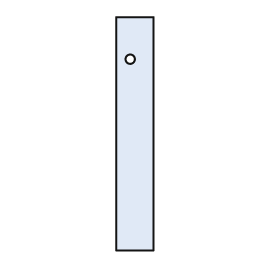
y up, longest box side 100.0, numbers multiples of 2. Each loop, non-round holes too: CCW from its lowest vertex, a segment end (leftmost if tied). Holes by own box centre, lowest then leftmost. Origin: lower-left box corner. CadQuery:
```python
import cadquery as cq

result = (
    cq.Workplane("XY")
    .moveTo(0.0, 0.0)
    .lineTo(16.0, 0.0)
    .lineTo(16.0, 100.0)
    .lineTo(0.0, 100.0)
    .close()
    .moveTo(6.0, 82.0)
    .circle(2.0)
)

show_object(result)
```